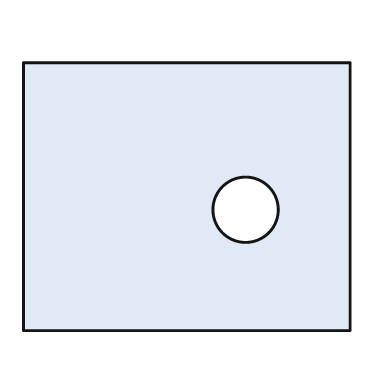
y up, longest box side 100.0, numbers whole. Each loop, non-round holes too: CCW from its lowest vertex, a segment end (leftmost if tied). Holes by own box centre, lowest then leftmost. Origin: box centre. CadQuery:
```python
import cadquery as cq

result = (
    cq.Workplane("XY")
    .moveTo(-50.0, -41.0)
    .lineTo(50.0, -41.0)
    .lineTo(50.0, 41.0)
    .lineTo(-50.0, 41.0)
    .close()
    .moveTo(18.0, -4.0)
    .circle(10.0)
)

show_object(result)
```